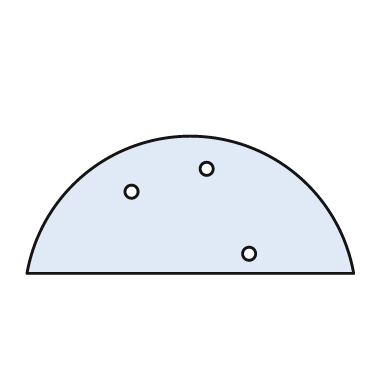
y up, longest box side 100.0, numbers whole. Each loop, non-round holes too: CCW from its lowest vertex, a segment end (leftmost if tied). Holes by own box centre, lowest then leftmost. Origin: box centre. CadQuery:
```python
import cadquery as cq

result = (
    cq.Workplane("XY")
    .moveTo(-50.0, -21.0)
    .lineTo(50.0, -21.0)
    .threePointArc((0.0, 21.0), (-50.0, -21.0))
    .close()
    .moveTo(18.0, -15.0)
    .circle(2.0)
    .moveTo(-18.0, 4.0)
    .circle(2.0)
    .moveTo(5.0, 11.0)
    .circle(2.0)
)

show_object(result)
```